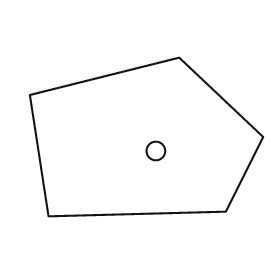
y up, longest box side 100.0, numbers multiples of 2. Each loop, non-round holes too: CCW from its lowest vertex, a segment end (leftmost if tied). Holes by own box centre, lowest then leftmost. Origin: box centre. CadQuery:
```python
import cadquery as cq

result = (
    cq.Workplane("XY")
    .moveTo(-42.0, -34.0)
    .lineTo(34.0, -32.0)
    .lineTo(50.0, 0.0)
    .lineTo(14.0, 34.0)
    .lineTo(-50.0, 18.0)
    .close()
    .moveTo(4.0, -6.0)
    .circle(4.0)
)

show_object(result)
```